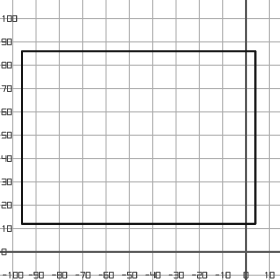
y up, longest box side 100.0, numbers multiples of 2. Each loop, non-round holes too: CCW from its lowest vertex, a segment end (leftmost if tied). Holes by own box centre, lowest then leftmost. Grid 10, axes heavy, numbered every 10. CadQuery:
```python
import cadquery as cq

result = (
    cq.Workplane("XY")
    .moveTo(-96.0, 12.0)
    .lineTo(4.0, 12.0)
    .lineTo(4.0, 86.0)
    .lineTo(-96.0, 86.0)
    .close()
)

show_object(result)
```